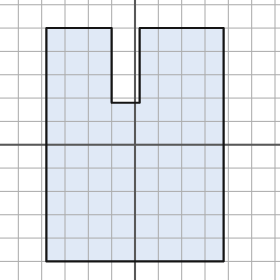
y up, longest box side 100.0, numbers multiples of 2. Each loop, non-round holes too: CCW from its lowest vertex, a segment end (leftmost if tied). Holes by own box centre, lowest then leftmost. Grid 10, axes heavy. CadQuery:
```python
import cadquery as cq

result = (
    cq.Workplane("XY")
    .moveTo(-38.0, -50.0)
    .lineTo(38.0, -50.0)
    .lineTo(38.0, 50.0)
    .lineTo(2.0, 50.0)
    .lineTo(2.0, 18.0)
    .lineTo(-10.0, 18.0)
    .lineTo(-10.0, 50.0)
    .lineTo(-38.0, 50.0)
    .close()
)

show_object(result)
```